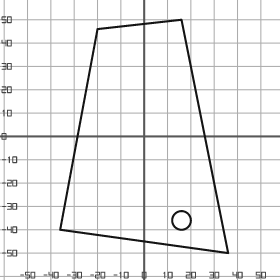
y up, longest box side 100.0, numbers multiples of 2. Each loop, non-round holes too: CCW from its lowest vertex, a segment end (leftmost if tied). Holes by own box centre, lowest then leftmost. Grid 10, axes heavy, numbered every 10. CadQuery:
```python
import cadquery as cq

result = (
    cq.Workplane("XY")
    .moveTo(36.0, -50.0)
    .lineTo(16.0, 50.0)
    .lineTo(-20.0, 46.0)
    .lineTo(-36.0, -40.0)
    .close()
    .moveTo(16.0, -36.0)
    .circle(4.0)
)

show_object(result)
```